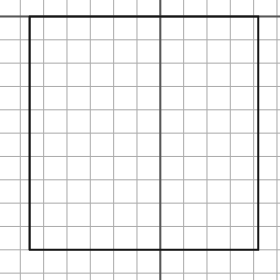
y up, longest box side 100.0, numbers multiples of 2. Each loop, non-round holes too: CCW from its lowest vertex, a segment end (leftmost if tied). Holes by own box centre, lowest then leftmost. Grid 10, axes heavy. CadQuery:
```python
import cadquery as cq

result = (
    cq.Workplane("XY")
    .moveTo(-56.0, -100.0)
    .lineTo(42.0, -100.0)
    .lineTo(42.0, 0.0)
    .lineTo(-56.0, 0.0)
    .close()
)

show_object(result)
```